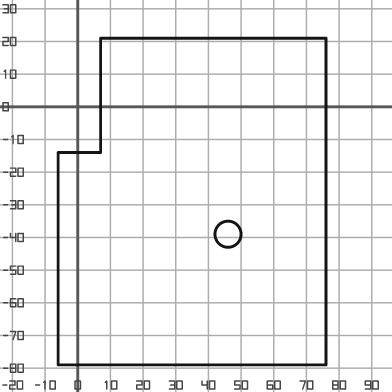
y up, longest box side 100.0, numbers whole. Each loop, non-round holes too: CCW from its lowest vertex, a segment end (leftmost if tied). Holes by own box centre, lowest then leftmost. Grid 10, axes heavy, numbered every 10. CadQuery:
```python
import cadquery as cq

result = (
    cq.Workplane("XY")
    .moveTo(-6.0, -79.0)
    .lineTo(76.0, -79.0)
    .lineTo(76.0, 21.0)
    .lineTo(7.0, 21.0)
    .lineTo(7.0, -14.0)
    .lineTo(-6.0, -14.0)
    .close()
    .moveTo(46.0, -39.0)
    .circle(4.0)
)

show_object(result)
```